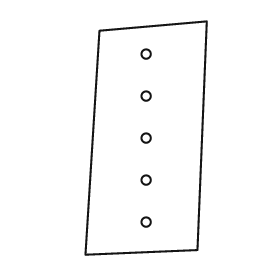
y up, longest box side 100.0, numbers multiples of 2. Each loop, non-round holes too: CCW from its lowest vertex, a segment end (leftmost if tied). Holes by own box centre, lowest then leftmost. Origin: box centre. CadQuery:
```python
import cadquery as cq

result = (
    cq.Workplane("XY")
    .moveTo(-26.0, -50.0)
    .lineTo(22.0, -48.0)
    .lineTo(26.0, 50.0)
    .lineTo(-20.0, 46.0)
    .close()
    .moveTo(0.0, -36.0)
    .circle(2.0)
    .moveTo(0.0, -18.0)
    .circle(2.0)
    .moveTo(0.0, 0.0)
    .circle(2.0)
    .moveTo(0.0, 18.0)
    .circle(2.0)
    .moveTo(0.0, 36.0)
    .circle(2.0)
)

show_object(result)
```